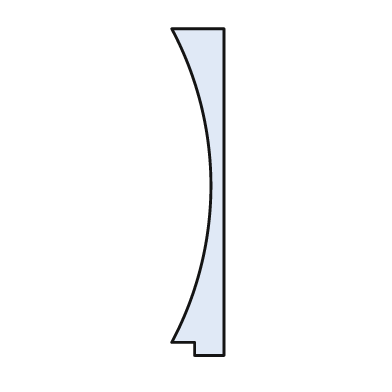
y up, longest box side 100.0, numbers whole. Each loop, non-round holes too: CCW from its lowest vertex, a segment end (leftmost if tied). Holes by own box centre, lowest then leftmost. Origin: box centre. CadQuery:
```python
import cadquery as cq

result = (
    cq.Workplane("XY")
    .moveTo(-1.0, -50.0)
    .lineTo(8.0, -50.0)
    .lineTo(8.0, 50.0)
    .lineTo(-8.0, 50.0)
    .threePointArc((4.0, 2.0), (-8.0, -46.0))
    .lineTo(-1.0, -46.0)
    .close()
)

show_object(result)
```